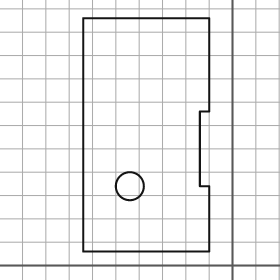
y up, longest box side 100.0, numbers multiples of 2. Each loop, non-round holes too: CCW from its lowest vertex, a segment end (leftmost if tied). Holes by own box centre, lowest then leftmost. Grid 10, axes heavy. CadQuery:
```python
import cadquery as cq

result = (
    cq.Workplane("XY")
    .moveTo(-64.0, 6.0)
    .lineTo(-10.0, 6.0)
    .lineTo(-10.0, 34.0)
    .lineTo(-14.0, 34.0)
    .lineTo(-14.0, 66.0)
    .lineTo(-10.0, 66.0)
    .lineTo(-10.0, 106.0)
    .lineTo(-64.0, 106.0)
    .close()
    .moveTo(-44.0, 34.0)
    .circle(6.0)
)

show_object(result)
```